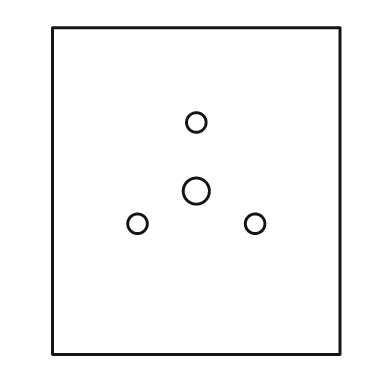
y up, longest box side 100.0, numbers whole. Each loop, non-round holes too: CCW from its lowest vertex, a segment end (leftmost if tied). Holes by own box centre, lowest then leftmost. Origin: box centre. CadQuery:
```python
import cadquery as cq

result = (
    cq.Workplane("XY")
    .moveTo(-44.0, -50.0)
    .lineTo(44.0, -50.0)
    .lineTo(44.0, 50.0)
    .lineTo(-44.0, 50.0)
    .close()
    .moveTo(-18.0, -10.0)
    .circle(3.0)
    .moveTo(18.0, -10.0)
    .circle(3.0)
    .moveTo(0.0, 0.0)
    .circle(4.0)
    .moveTo(0.0, 21.0)
    .circle(3.0)
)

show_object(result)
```